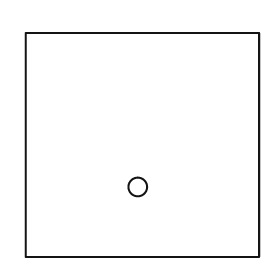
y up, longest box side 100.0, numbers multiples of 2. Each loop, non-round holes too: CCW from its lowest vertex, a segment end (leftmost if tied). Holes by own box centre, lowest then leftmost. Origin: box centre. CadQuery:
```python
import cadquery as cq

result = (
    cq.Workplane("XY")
    .moveTo(-50.0, -48.0)
    .lineTo(50.0, -48.0)
    .lineTo(50.0, 48.0)
    .lineTo(-50.0, 48.0)
    .close()
    .moveTo(-2.0, -18.0)
    .circle(4.0)
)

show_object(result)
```